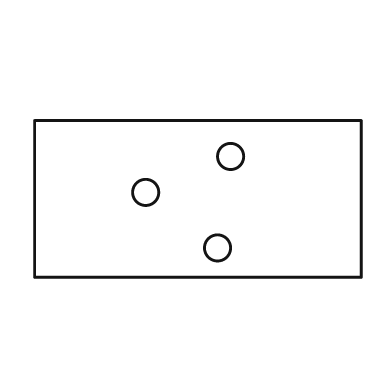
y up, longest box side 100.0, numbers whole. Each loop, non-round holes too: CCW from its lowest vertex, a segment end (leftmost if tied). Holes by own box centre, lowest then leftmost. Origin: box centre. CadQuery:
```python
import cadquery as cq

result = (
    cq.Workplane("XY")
    .moveTo(-50.0, -24.0)
    .lineTo(50.0, -24.0)
    .lineTo(50.0, 24.0)
    .lineTo(-50.0, 24.0)
    .close()
    .moveTo(6.0, -15.0)
    .circle(4.0)
    .moveTo(-16.0, 2.0)
    .circle(4.0)
    .moveTo(10.0, 13.0)
    .circle(4.0)
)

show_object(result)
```